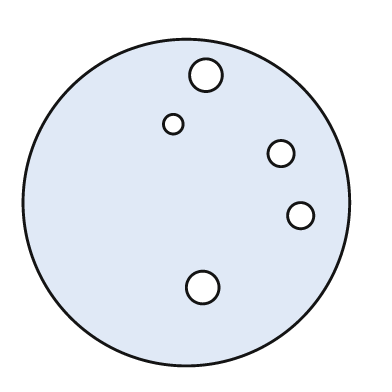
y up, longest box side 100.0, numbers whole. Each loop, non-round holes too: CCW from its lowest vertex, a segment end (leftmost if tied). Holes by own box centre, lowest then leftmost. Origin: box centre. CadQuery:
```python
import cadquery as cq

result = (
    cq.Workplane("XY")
    .moveTo(0.0, 0.0)
    .circle(50.0)
    .moveTo(5.0, -26.0)
    .circle(5.0)
    .moveTo(35.0, -4.0)
    .circle(4.0)
    .moveTo(29.0, 15.0)
    .circle(4.0)
    .moveTo(-4.0, 24.0)
    .circle(3.0)
    .moveTo(6.0, 39.0)
    .circle(5.0)
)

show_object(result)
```